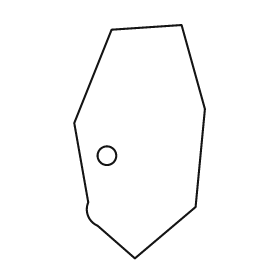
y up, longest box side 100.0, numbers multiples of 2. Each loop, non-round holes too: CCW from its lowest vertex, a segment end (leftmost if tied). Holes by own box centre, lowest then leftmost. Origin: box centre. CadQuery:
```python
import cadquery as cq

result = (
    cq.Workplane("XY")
    .moveTo(-2.0, -50.0)
    .lineTo(24.0, -28.0)
    .lineTo(28.0, 14.0)
    .lineTo(18.0, 50.0)
    .lineTo(-12.0, 48.0)
    .lineTo(-28.0, 8.0)
    .lineTo(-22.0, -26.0)
    .threePointArc((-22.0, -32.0), (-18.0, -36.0))
    .close()
    .moveTo(-14.0, -6.0)
    .circle(4.0)
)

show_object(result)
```